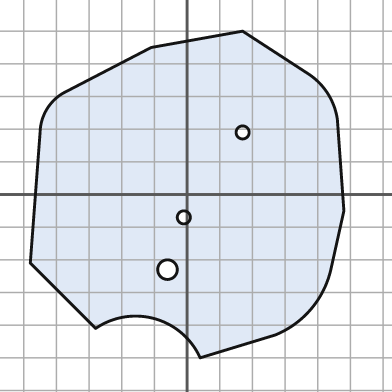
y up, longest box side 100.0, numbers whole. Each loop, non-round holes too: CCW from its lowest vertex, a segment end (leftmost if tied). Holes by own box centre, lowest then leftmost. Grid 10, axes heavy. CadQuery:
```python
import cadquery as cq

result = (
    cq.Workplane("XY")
    .moveTo(4.0, -50.0)
    .lineTo(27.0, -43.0)
    .threePointArc((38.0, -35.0), (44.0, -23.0))
    .lineTo(48.0, -5.0)
    .lineTo(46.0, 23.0)
    .threePointArc((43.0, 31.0), (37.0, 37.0))
    .lineTo(17.0, 50.0)
    .lineTo(-11.0, 45.0)
    .lineTo(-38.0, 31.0)
    .threePointArc((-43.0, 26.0), (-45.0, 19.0))
    .lineTo(-48.0, -21.0)
    .lineTo(-28.0, -41.0)
    .threePointArc((-10.0, -38.0), (4.0, -50.0))
    .close()
    .moveTo(-6.0, -23.0)
    .circle(3.0)
    .moveTo(-1.0, -7.0)
    .circle(2.0)
    .moveTo(17.0, 19.0)
    .circle(2.0)
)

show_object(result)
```